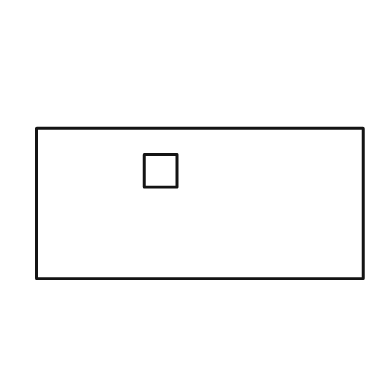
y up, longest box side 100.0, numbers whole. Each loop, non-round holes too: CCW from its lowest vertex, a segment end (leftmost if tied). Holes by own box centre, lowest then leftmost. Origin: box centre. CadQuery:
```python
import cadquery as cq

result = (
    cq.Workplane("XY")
    .moveTo(-50.0, -23.0)
    .lineTo(50.0, -23.0)
    .lineTo(50.0, 23.0)
    .lineTo(-50.0, 23.0)
    .close()
    .moveTo(-17.0, 5.0)
    .lineTo(-7.0, 5.0)
    .lineTo(-7.0, 15.0)
    .lineTo(-17.0, 15.0)
    .close()
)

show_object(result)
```